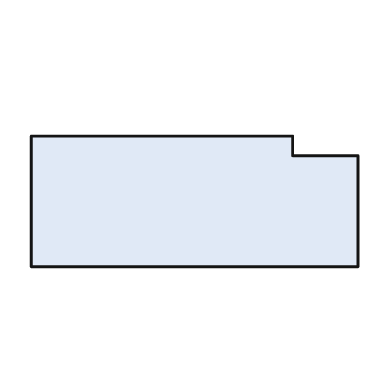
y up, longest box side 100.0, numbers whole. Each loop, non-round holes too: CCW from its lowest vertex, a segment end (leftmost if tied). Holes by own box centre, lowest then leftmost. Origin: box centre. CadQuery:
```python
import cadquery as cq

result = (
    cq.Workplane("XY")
    .moveTo(-50.0, -20.0)
    .lineTo(50.0, -20.0)
    .lineTo(50.0, 14.0)
    .lineTo(30.0, 14.0)
    .lineTo(30.0, 20.0)
    .lineTo(-50.0, 20.0)
    .close()
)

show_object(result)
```